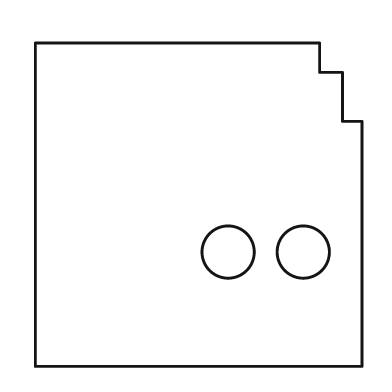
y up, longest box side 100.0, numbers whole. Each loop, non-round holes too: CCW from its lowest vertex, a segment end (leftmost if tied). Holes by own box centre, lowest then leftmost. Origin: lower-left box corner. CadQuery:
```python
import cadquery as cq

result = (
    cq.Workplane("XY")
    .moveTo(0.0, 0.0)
    .lineTo(100.0, 0.0)
    .lineTo(100.0, 75.0)
    .lineTo(94.0, 75.0)
    .lineTo(94.0, 90.0)
    .lineTo(87.0, 90.0)
    .lineTo(87.0, 99.0)
    .lineTo(0.0, 99.0)
    .close()
    .moveTo(59.0, 35.0)
    .circle(8.0)
    .moveTo(82.0, 35.0)
    .circle(8.0)
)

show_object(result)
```